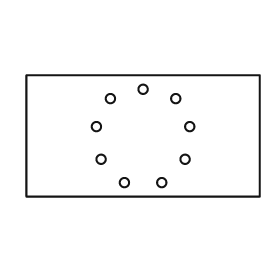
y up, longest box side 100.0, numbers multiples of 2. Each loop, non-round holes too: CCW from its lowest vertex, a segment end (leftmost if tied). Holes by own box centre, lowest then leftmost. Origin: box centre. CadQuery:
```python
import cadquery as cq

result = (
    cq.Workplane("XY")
    .moveTo(-50.0, -26.0)
    .lineTo(50.0, -26.0)
    .lineTo(50.0, 26.0)
    .lineTo(-50.0, 26.0)
    .close()
    .moveTo(-8.0, -20.0)
    .circle(2.0)
    .moveTo(8.0, -20.0)
    .circle(2.0)
    .moveTo(-18.0, -10.0)
    .circle(2.0)
    .moveTo(18.0, -10.0)
    .circle(2.0)
    .moveTo(-20.0, 4.0)
    .circle(2.0)
    .moveTo(20.0, 4.0)
    .circle(2.0)
    .moveTo(-14.0, 16.0)
    .circle(2.0)
    .moveTo(14.0, 16.0)
    .circle(2.0)
    .moveTo(0.0, 20.0)
    .circle(2.0)
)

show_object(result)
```